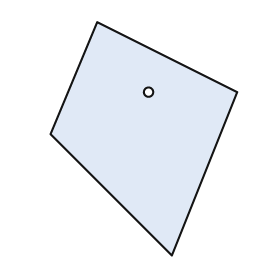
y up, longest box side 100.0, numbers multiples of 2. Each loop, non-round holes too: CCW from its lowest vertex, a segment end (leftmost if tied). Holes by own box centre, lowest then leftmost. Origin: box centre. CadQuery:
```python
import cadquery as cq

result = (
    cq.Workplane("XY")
    .moveTo(12.0, -50.0)
    .lineTo(40.0, 20.0)
    .lineTo(-20.0, 50.0)
    .lineTo(-40.0, 2.0)
    .close()
    .moveTo(2.0, 20.0)
    .circle(2.0)
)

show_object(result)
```